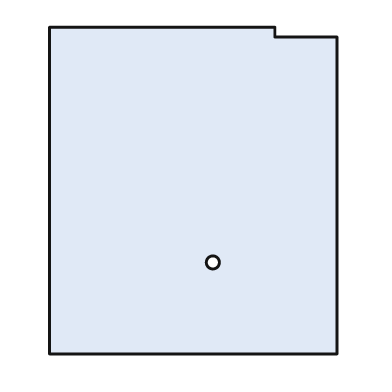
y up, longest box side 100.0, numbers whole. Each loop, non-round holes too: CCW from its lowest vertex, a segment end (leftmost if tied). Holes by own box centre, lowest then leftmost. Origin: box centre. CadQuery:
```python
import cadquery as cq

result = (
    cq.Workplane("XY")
    .moveTo(-44.0, -50.0)
    .lineTo(44.0, -50.0)
    .lineTo(44.0, 47.0)
    .lineTo(25.0, 47.0)
    .lineTo(25.0, 50.0)
    .lineTo(-44.0, 50.0)
    .close()
    .moveTo(6.0, -22.0)
    .circle(2.0)
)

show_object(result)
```